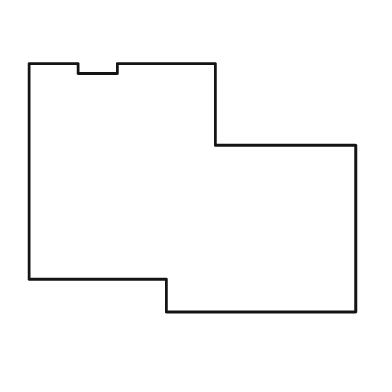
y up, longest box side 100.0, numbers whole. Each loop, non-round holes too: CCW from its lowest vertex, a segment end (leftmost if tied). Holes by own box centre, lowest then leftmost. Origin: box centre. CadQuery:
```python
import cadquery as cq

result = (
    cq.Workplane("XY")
    .moveTo(-8.0, -38.0)
    .lineTo(50.0, -38.0)
    .lineTo(50.0, 13.0)
    .lineTo(7.0, 13.0)
    .lineTo(7.0, 38.0)
    .lineTo(-23.0, 38.0)
    .lineTo(-23.0, 35.0)
    .lineTo(-35.0, 35.0)
    .lineTo(-35.0, 38.0)
    .lineTo(-50.0, 38.0)
    .lineTo(-50.0, -28.0)
    .lineTo(-8.0, -28.0)
    .close()
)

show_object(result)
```